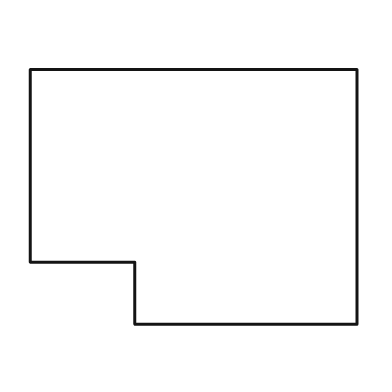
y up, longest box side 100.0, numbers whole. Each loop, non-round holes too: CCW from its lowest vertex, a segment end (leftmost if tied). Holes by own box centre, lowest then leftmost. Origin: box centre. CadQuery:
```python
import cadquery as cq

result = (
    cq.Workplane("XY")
    .moveTo(-18.0, -39.0)
    .lineTo(50.0, -39.0)
    .lineTo(50.0, 39.0)
    .lineTo(-50.0, 39.0)
    .lineTo(-50.0, -20.0)
    .lineTo(-18.0, -20.0)
    .close()
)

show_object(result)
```